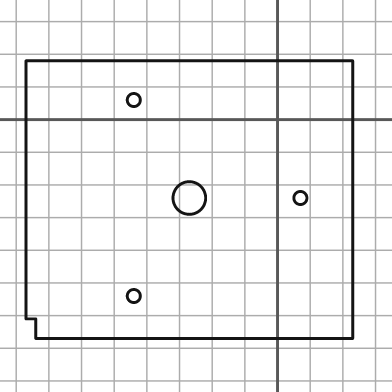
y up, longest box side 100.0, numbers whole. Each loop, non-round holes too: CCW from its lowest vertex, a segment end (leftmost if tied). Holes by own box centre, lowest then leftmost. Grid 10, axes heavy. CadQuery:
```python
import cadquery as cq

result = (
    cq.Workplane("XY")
    .moveTo(-74.0, -67.0)
    .lineTo(23.0, -67.0)
    .lineTo(23.0, 18.0)
    .lineTo(-77.0, 18.0)
    .lineTo(-77.0, -61.0)
    .lineTo(-74.0, -61.0)
    .close()
    .moveTo(-44.0, -54.0)
    .circle(2.0)
    .moveTo(-27.0, -24.0)
    .circle(5.0)
    .moveTo(7.0, -24.0)
    .circle(2.0)
    .moveTo(-44.0, 6.0)
    .circle(2.0)
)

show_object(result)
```